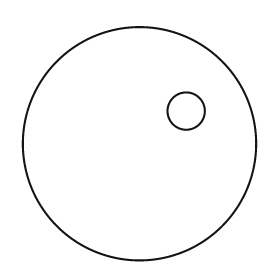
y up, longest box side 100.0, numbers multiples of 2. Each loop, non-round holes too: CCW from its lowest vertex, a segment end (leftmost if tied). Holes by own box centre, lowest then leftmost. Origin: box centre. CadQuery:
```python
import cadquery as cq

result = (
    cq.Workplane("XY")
    .moveTo(0.0, 0.0)
    .circle(50.0)
    .moveTo(20.0, 14.0)
    .circle(8.0)
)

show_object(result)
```